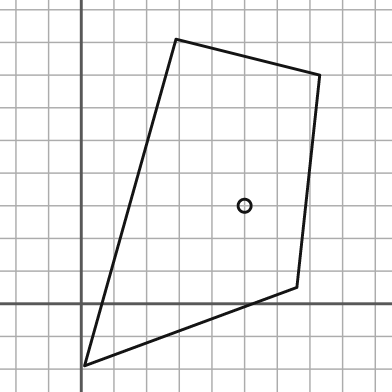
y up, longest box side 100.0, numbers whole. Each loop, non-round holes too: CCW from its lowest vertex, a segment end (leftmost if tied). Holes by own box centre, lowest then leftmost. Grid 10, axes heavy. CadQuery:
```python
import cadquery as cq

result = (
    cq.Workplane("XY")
    .moveTo(1.0, -19.0)
    .lineTo(66.0, 5.0)
    .lineTo(73.0, 70.0)
    .lineTo(29.0, 81.0)
    .close()
    .moveTo(50.0, 30.0)
    .circle(2.0)
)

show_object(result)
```